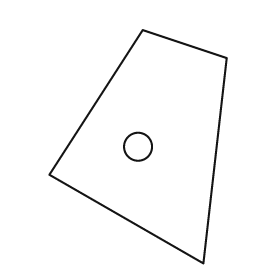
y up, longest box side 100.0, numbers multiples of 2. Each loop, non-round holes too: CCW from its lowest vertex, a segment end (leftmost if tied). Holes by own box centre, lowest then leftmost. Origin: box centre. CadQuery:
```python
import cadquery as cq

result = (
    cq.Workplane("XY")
    .moveTo(28.0, -50.0)
    .lineTo(38.0, 38.0)
    .lineTo(2.0, 50.0)
    .lineTo(-38.0, -12.0)
    .close()
    .moveTo(0.0, 0.0)
    .circle(6.0)
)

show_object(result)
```